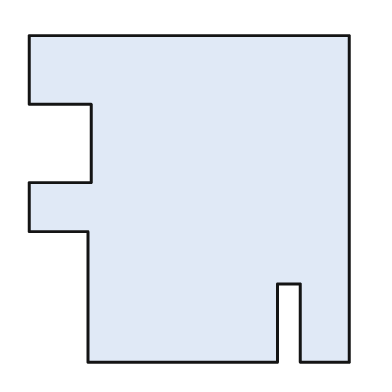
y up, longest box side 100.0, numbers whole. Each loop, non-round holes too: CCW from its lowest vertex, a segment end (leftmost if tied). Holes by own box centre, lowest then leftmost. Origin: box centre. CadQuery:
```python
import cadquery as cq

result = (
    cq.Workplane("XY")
    .moveTo(-31.0, -50.0)
    .lineTo(27.0, -50.0)
    .lineTo(27.0, -26.0)
    .lineTo(34.0, -26.0)
    .lineTo(34.0, -50.0)
    .lineTo(49.0, -50.0)
    .lineTo(49.0, 50.0)
    .lineTo(-49.0, 50.0)
    .lineTo(-49.0, 29.0)
    .lineTo(-30.0, 29.0)
    .lineTo(-30.0, 5.0)
    .lineTo(-49.0, 5.0)
    .lineTo(-49.0, -10.0)
    .lineTo(-31.0, -10.0)
    .close()
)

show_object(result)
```